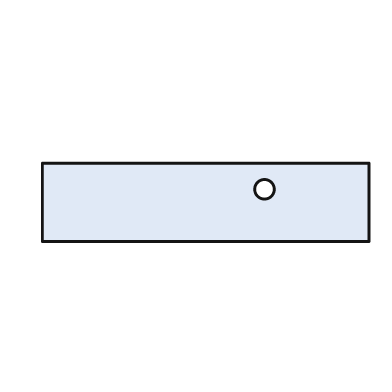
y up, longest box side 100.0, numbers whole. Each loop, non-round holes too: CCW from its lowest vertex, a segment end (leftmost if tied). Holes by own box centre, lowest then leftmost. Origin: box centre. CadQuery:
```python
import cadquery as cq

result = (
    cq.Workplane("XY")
    .moveTo(-50.0, -12.0)
    .lineTo(50.0, -12.0)
    .lineTo(50.0, 12.0)
    .lineTo(-50.0, 12.0)
    .close()
    .moveTo(18.0, 4.0)
    .circle(3.0)
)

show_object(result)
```